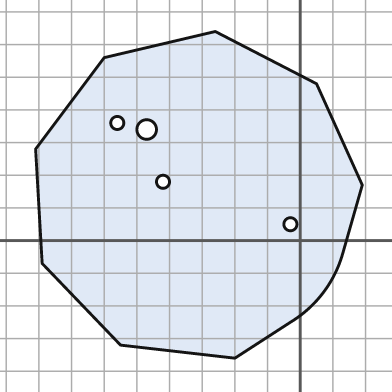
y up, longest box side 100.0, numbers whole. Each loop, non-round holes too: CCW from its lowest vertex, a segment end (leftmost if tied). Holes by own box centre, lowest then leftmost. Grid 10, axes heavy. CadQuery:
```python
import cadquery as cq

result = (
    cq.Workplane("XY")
    .moveTo(-20.0, -36.0)
    .lineTo(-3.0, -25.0)
    .threePointArc((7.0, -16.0), (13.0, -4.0))
    .lineTo(19.0, 17.0)
    .lineTo(5.0, 48.0)
    .lineTo(-26.0, 64.0)
    .lineTo(-60.0, 56.0)
    .lineTo(-81.0, 28.0)
    .lineTo(-79.0, -7.0)
    .lineTo(-55.0, -32.0)
    .close()
    .moveTo(-3.0, 5.0)
    .circle(2.0)
    .moveTo(-42.0, 18.0)
    .circle(2.0)
    .moveTo(-47.0, 34.0)
    .circle(3.0)
    .moveTo(-56.0, 36.0)
    .circle(2.0)
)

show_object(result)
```